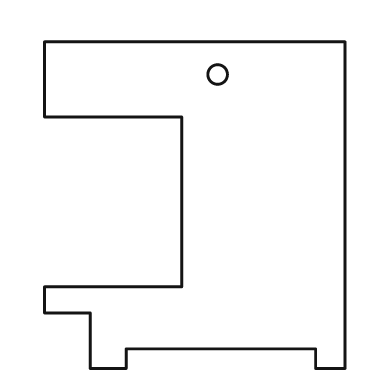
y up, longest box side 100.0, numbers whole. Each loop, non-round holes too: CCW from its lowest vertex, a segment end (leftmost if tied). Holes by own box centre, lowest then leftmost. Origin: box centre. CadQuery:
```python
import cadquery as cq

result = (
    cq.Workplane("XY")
    .moveTo(-32.0, -50.0)
    .lineTo(-21.0, -50.0)
    .lineTo(-21.0, -44.0)
    .lineTo(37.0, -44.0)
    .lineTo(37.0, -50.0)
    .lineTo(46.0, -50.0)
    .lineTo(46.0, 50.0)
    .lineTo(-46.0, 50.0)
    .lineTo(-46.0, 27.0)
    .lineTo(-4.0, 27.0)
    .lineTo(-4.0, -25.0)
    .lineTo(-46.0, -25.0)
    .lineTo(-46.0, -33.0)
    .lineTo(-32.0, -33.0)
    .close()
    .moveTo(7.0, 40.0)
    .circle(3.0)
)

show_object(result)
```